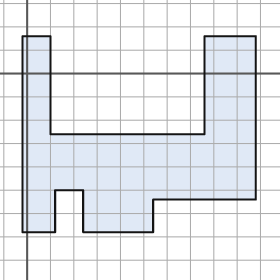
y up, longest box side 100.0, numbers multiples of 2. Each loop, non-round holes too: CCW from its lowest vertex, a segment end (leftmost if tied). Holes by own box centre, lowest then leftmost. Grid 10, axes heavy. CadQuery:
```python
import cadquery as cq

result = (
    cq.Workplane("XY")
    .moveTo(-2.0, -68.0)
    .lineTo(12.0, -68.0)
    .lineTo(12.0, -50.0)
    .lineTo(24.0, -50.0)
    .lineTo(24.0, -68.0)
    .lineTo(54.0, -68.0)
    .lineTo(54.0, -54.0)
    .lineTo(98.0, -54.0)
    .lineTo(98.0, 16.0)
    .lineTo(76.0, 16.0)
    .lineTo(76.0, -26.0)
    .lineTo(10.0, -26.0)
    .lineTo(10.0, 16.0)
    .lineTo(-2.0, 16.0)
    .close()
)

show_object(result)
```